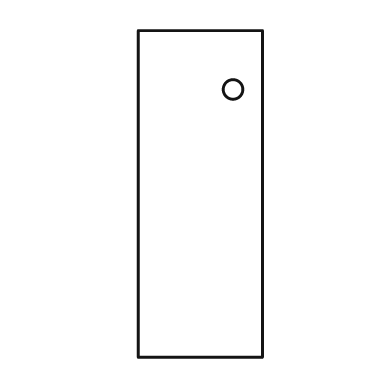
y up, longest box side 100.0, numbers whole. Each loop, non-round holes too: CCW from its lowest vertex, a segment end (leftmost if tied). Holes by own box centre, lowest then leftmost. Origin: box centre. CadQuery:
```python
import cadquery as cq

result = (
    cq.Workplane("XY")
    .moveTo(-19.0, -50.0)
    .lineTo(19.0, -50.0)
    .lineTo(19.0, 50.0)
    .lineTo(-19.0, 50.0)
    .close()
    .moveTo(10.0, 32.0)
    .circle(3.0)
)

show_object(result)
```